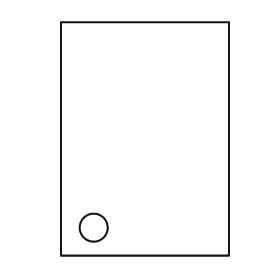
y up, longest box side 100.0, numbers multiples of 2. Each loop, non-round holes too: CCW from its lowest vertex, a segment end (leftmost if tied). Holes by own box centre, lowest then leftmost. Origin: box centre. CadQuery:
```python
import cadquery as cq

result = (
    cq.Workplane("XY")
    .moveTo(-36.0, -50.0)
    .lineTo(36.0, -50.0)
    .lineTo(36.0, 50.0)
    .lineTo(-36.0, 50.0)
    .close()
    .moveTo(-22.0, -38.0)
    .circle(6.0)
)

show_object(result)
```